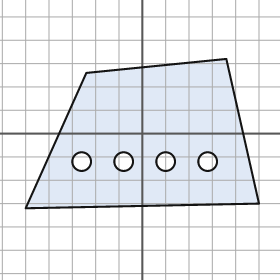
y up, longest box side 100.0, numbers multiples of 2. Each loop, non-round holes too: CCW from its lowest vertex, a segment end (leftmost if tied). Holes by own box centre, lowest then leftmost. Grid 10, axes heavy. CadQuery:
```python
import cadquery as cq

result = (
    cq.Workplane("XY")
    .moveTo(-50.0, -32.0)
    .lineTo(50.0, -30.0)
    .lineTo(36.0, 32.0)
    .lineTo(-24.0, 26.0)
    .close()
    .moveTo(-26.0, -12.0)
    .circle(4.0)
    .moveTo(-8.0, -12.0)
    .circle(4.0)
    .moveTo(10.0, -12.0)
    .circle(4.0)
    .moveTo(28.0, -12.0)
    .circle(4.0)
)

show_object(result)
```